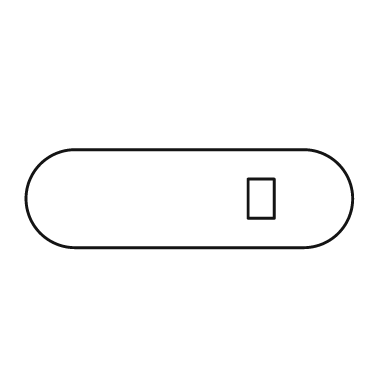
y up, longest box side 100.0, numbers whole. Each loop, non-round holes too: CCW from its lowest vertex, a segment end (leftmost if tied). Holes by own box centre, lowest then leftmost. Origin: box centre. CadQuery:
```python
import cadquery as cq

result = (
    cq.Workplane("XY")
    .moveTo(-35.0, -15.0)
    .lineTo(35.0, -15.0)
    .threePointArc((50.0, 0.0), (35.0, 15.0))
    .lineTo(-35.0, 15.0)
    .threePointArc((-50.0, 0.0), (-35.0, -15.0))
    .close()
    .moveTo(18.0, -6.0)
    .lineTo(26.0, -6.0)
    .lineTo(26.0, 6.0)
    .lineTo(18.0, 6.0)
    .close()
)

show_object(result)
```